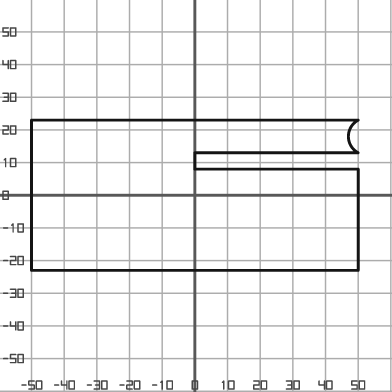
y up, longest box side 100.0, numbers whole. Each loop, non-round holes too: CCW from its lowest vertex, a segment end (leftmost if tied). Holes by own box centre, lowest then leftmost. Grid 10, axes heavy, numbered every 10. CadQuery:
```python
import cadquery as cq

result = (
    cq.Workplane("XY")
    .moveTo(-50.0, -23.0)
    .lineTo(50.0, -23.0)
    .lineTo(50.0, 8.0)
    .lineTo(0.0, 8.0)
    .lineTo(0.0, 13.0)
    .lineTo(50.0, 13.0)
    .threePointArc((47.0, 18.0), (50.0, 23.0))
    .lineTo(-50.0, 23.0)
    .close()
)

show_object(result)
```